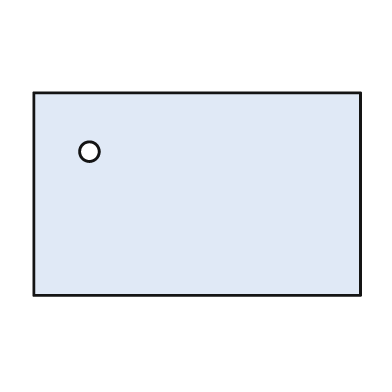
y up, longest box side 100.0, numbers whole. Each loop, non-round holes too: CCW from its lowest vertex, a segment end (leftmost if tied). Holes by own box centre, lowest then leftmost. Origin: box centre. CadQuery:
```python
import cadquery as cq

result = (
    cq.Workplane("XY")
    .moveTo(-50.0, -31.0)
    .lineTo(50.0, -31.0)
    .lineTo(50.0, 31.0)
    .lineTo(-50.0, 31.0)
    .close()
    .moveTo(-33.0, 13.0)
    .circle(3.0)
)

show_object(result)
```